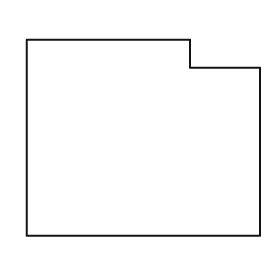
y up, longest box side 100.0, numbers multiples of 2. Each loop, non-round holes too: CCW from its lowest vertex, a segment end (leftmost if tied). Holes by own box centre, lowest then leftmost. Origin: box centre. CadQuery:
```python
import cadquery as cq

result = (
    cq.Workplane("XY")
    .moveTo(-50.0, -42.0)
    .lineTo(50.0, -42.0)
    .lineTo(50.0, 30.0)
    .lineTo(20.0, 30.0)
    .lineTo(20.0, 42.0)
    .lineTo(-50.0, 42.0)
    .close()
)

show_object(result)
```